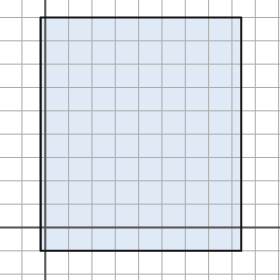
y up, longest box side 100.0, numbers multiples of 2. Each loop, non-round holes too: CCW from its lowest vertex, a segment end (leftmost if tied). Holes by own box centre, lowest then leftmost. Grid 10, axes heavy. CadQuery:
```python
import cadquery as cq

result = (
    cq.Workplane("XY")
    .moveTo(-2.0, -10.0)
    .lineTo(84.0, -10.0)
    .lineTo(84.0, 90.0)
    .lineTo(-2.0, 90.0)
    .close()
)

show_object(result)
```